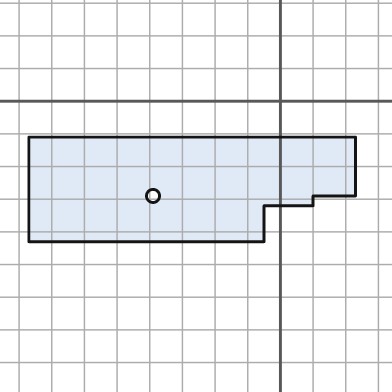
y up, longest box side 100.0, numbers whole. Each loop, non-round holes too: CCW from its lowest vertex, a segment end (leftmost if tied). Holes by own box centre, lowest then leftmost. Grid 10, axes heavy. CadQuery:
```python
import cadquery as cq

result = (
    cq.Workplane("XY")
    .moveTo(-77.0, -43.0)
    .lineTo(-5.0, -43.0)
    .lineTo(-5.0, -32.0)
    .lineTo(10.0, -32.0)
    .lineTo(10.0, -29.0)
    .lineTo(23.0, -29.0)
    .lineTo(23.0, -11.0)
    .lineTo(-77.0, -11.0)
    .close()
    .moveTo(-39.0, -29.0)
    .circle(2.0)
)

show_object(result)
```